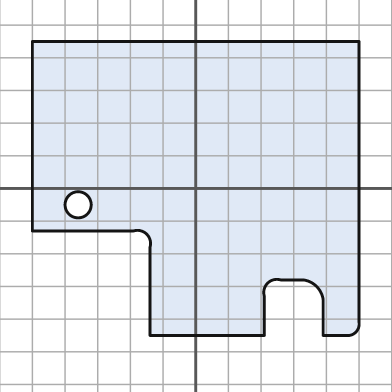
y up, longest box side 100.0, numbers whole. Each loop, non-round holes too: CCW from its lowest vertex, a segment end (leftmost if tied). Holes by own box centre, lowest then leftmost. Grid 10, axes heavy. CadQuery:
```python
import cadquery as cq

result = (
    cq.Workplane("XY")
    .moveTo(-14.0, -45.0)
    .lineTo(21.0, -45.0)
    .lineTo(21.0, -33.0)
    .threePointArc((22.0, -29.0), (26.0, -28.0))
    .lineTo(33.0, -28.0)
    .threePointArc((37.0, -30.0), (39.0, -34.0))
    .lineTo(39.0, -45.0)
    .lineTo(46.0, -45.0)
    .threePointArc((49.0, -44.0), (50.0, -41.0))
    .lineTo(50.0, 45.0)
    .lineTo(-50.0, 45.0)
    .lineTo(-50.0, -13.0)
    .lineTo(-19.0, -13.0)
    .threePointArc((-15.0, -14.0), (-14.0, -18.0))
    .close()
    .moveTo(-36.0, -5.0)
    .circle(4.0)
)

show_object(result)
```